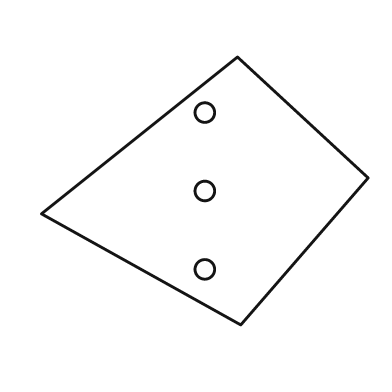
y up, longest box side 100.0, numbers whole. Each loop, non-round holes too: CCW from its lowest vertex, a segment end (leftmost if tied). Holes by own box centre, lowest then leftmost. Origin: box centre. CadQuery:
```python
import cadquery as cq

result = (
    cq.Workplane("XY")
    .moveTo(11.0, -41.0)
    .lineTo(50.0, 4.0)
    .lineTo(10.0, 41.0)
    .lineTo(-50.0, -7.0)
    .close()
    .moveTo(0.0, -24.0)
    .circle(3.0)
    .moveTo(0.0, 0.0)
    .circle(3.0)
    .moveTo(0.0, 24.0)
    .circle(3.0)
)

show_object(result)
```